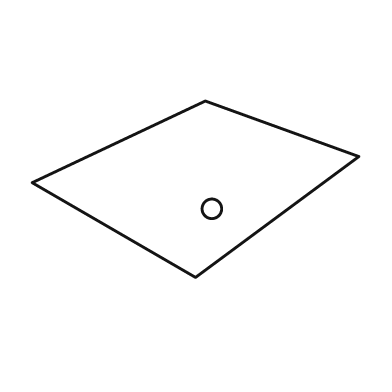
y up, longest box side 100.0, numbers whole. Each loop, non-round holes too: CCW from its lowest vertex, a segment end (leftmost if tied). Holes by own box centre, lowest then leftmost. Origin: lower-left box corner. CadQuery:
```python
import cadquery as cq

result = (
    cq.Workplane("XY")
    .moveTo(50.0, 0.0)
    .lineTo(100.0, 37.0)
    .lineTo(53.0, 54.0)
    .lineTo(0.0, 29.0)
    .close()
    .moveTo(55.0, 21.0)
    .circle(3.0)
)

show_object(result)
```